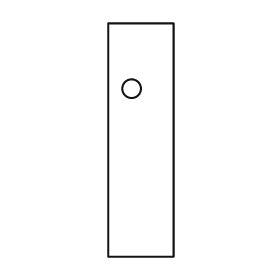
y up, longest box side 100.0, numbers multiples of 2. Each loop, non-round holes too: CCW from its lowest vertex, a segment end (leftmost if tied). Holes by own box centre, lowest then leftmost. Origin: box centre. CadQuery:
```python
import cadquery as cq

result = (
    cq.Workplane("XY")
    .moveTo(-14.0, -50.0)
    .lineTo(14.0, -50.0)
    .lineTo(14.0, 50.0)
    .lineTo(-14.0, 50.0)
    .close()
    .moveTo(-4.0, 22.0)
    .circle(4.0)
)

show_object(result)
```